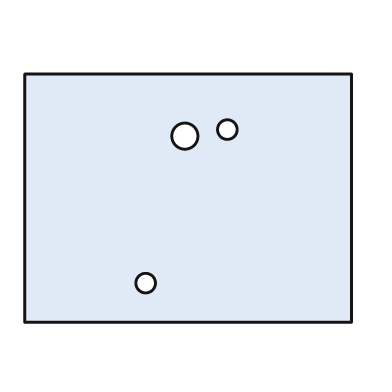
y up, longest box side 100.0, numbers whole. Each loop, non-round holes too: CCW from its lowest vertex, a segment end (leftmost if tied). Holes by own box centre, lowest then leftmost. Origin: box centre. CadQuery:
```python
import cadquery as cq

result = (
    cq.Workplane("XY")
    .moveTo(-50.0, -38.0)
    .lineTo(50.0, -38.0)
    .lineTo(50.0, 38.0)
    .lineTo(-50.0, 38.0)
    .close()
    .moveTo(-13.0, -26.0)
    .circle(3.0)
    .moveTo(-1.0, 19.0)
    .circle(4.0)
    .moveTo(12.0, 21.0)
    .circle(3.0)
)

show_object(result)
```